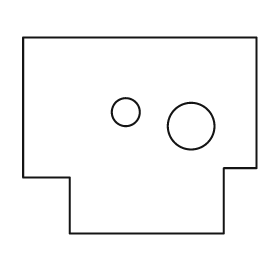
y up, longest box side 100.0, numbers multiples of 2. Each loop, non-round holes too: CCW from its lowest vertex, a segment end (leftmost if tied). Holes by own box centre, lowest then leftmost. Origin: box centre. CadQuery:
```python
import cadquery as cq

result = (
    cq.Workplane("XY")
    .moveTo(-30.0, -42.0)
    .lineTo(36.0, -42.0)
    .lineTo(36.0, -14.0)
    .lineTo(50.0, -14.0)
    .lineTo(50.0, 42.0)
    .lineTo(-50.0, 42.0)
    .lineTo(-50.0, -18.0)
    .lineTo(-30.0, -18.0)
    .close()
    .moveTo(22.0, 4.0)
    .circle(10.0)
    .moveTo(-6.0, 10.0)
    .circle(6.0)
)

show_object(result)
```